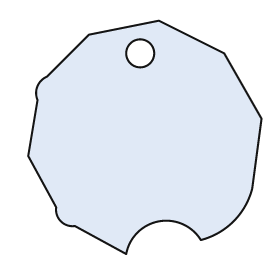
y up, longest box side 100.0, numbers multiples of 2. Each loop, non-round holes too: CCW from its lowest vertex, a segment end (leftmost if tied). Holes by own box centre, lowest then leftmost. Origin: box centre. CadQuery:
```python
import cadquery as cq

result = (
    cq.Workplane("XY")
    .moveTo(-8.0, -50.0)
    .threePointArc((6.0, -36.0), (24.0, -44.0))
    .threePointArc((38.0, -36.0), (46.0, -22.0))
    .lineTo(50.0, 8.0)
    .lineTo(34.0, 36.0)
    .lineTo(6.0, 50.0)
    .lineTo(-24.0, 44.0)
    .lineTo(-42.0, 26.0)
    .threePointArc((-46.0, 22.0), (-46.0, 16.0))
    .lineTo(-50.0, -8.0)
    .lineTo(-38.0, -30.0)
    .threePointArc((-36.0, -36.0), (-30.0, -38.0))
    .close()
    .moveTo(-2.0, 36.0)
    .circle(6.0)
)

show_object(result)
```